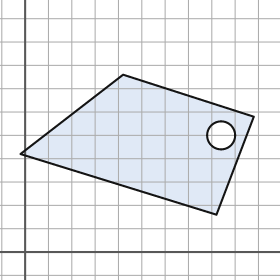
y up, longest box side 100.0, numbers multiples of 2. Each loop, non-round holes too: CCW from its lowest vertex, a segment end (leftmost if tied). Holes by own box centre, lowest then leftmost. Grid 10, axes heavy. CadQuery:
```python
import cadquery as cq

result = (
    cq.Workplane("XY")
    .moveTo(82.0, 16.0)
    .lineTo(98.0, 58.0)
    .lineTo(42.0, 76.0)
    .lineTo(-2.0, 42.0)
    .close()
    .moveTo(84.0, 50.0)
    .circle(6.0)
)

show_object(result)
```